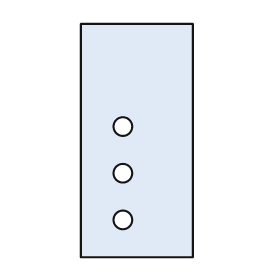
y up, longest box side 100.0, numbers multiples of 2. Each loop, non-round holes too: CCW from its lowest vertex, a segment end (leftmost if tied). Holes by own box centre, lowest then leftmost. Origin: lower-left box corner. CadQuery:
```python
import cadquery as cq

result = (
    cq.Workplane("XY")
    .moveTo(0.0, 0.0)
    .lineTo(48.0, 0.0)
    .lineTo(48.0, 100.0)
    .lineTo(0.0, 100.0)
    .close()
    .moveTo(18.0, 16.0)
    .circle(4.0)
    .moveTo(18.0, 36.0)
    .circle(4.0)
    .moveTo(18.0, 56.0)
    .circle(4.0)
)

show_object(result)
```